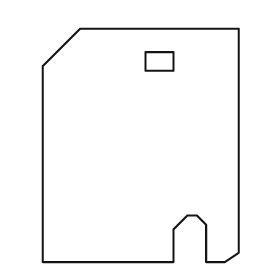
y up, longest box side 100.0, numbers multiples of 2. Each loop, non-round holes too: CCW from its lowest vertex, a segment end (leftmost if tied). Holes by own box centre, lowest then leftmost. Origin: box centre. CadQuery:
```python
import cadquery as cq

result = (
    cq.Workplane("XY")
    .moveTo(-42.0, -50.0)
    .lineTo(14.0, -50.0)
    .lineTo(14.0, -36.0)
    .lineTo(20.0, -30.0)
    .lineTo(24.0, -30.0)
    .lineTo(28.0, -34.0)
    .lineTo(28.0, -50.0)
    .lineTo(36.0, -50.0)
    .lineTo(42.0, -46.0)
    .lineTo(42.0, 50.0)
    .lineTo(-26.0, 50.0)
    .lineTo(-42.0, 34.0)
    .close()
    .moveTo(2.0, 32.0)
    .lineTo(14.0, 32.0)
    .lineTo(14.0, 40.0)
    .lineTo(2.0, 40.0)
    .close()
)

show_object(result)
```